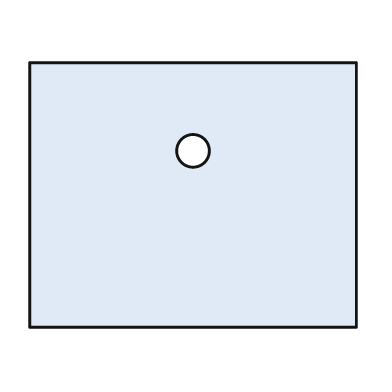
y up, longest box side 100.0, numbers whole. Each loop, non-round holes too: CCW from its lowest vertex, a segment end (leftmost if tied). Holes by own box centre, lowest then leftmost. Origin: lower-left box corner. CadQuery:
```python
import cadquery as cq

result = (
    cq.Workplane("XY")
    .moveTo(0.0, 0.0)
    .lineTo(100.0, 0.0)
    .lineTo(100.0, 81.0)
    .lineTo(0.0, 81.0)
    .close()
    .moveTo(50.0, 54.0)
    .circle(5.0)
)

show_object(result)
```